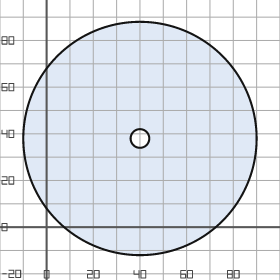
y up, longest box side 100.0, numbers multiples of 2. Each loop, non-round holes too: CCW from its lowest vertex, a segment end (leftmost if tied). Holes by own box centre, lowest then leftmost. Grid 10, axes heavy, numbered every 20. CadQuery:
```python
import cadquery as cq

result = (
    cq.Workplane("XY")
    .moveTo(40.0, 38.0)
    .circle(50.0)
    .moveTo(40.0, 38.0)
    .circle(4.0)
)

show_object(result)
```